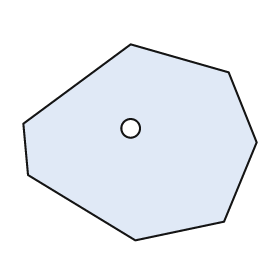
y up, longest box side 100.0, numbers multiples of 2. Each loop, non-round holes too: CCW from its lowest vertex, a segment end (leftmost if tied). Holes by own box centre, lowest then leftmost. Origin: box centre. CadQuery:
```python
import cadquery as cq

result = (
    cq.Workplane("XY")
    .moveTo(-2.0, -42.0)
    .lineTo(36.0, -34.0)
    .lineTo(50.0, 0.0)
    .lineTo(38.0, 30.0)
    .lineTo(-4.0, 42.0)
    .lineTo(-50.0, 8.0)
    .lineTo(-48.0, -14.0)
    .close()
    .moveTo(-4.0, 6.0)
    .circle(4.0)
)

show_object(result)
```